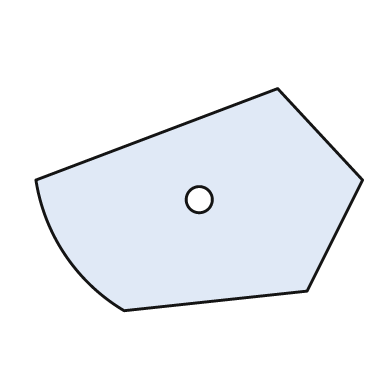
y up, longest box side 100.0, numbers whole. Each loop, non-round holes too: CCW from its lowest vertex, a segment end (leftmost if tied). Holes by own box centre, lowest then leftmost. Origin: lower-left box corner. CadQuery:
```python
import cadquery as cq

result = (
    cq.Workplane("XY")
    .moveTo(27.0, 0.0)
    .lineTo(83.0, 6.0)
    .lineTo(100.0, 40.0)
    .lineTo(74.0, 68.0)
    .lineTo(0.0, 40.0)
    .threePointArc((9.0, 17.0), (27.0, 0.0))
    .close()
    .moveTo(50.0, 34.0)
    .circle(4.0)
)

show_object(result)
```